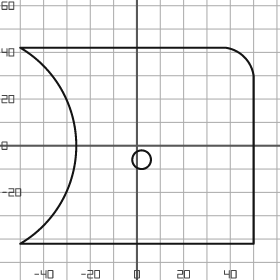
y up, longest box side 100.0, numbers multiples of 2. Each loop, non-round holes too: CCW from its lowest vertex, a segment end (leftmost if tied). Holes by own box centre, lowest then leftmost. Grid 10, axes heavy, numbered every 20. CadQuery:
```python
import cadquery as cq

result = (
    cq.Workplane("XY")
    .moveTo(-50.0, -42.0)
    .lineTo(50.0, -42.0)
    .lineTo(50.0, 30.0)
    .threePointArc((46.0, 38.0), (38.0, 42.0))
    .lineTo(-50.0, 42.0)
    .threePointArc((-26.0, 0.0), (-50.0, -42.0))
    .close()
    .moveTo(2.0, -6.0)
    .circle(4.0)
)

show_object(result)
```